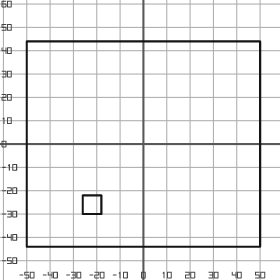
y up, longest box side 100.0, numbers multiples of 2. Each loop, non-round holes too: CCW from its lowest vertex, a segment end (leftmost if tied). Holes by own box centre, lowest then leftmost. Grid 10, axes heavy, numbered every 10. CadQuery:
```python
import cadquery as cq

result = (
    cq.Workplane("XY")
    .moveTo(-50.0, -44.0)
    .lineTo(50.0, -44.0)
    .lineTo(50.0, 44.0)
    .lineTo(-50.0, 44.0)
    .close()
    .moveTo(-26.0, -30.0)
    .lineTo(-18.0, -30.0)
    .lineTo(-18.0, -22.0)
    .lineTo(-26.0, -22.0)
    .close()
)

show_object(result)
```